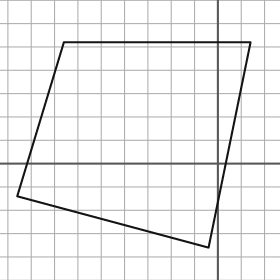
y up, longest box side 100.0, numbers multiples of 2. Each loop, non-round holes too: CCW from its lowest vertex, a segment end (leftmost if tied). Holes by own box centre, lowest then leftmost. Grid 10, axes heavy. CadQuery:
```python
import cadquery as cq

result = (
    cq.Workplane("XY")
    .moveTo(-4.0, -36.0)
    .lineTo(14.0, 52.0)
    .lineTo(-66.0, 52.0)
    .lineTo(-86.0, -14.0)
    .close()
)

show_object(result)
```